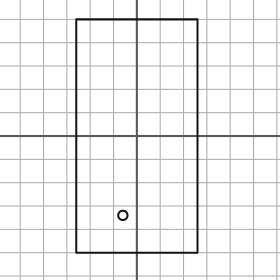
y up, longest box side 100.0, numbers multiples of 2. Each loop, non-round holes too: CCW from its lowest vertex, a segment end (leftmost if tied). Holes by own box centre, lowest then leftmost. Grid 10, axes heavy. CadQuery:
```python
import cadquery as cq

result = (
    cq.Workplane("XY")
    .moveTo(-26.0, -50.0)
    .lineTo(26.0, -50.0)
    .lineTo(26.0, 50.0)
    .lineTo(-26.0, 50.0)
    .close()
    .moveTo(-6.0, -34.0)
    .circle(2.0)
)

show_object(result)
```